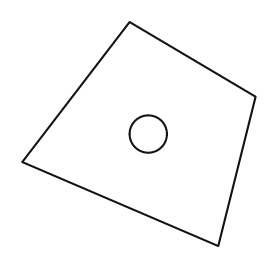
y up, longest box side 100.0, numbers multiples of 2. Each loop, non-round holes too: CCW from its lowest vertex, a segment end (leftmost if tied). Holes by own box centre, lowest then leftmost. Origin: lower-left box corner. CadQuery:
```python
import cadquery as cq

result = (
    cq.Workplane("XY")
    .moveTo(84.0, 0.0)
    .lineTo(100.0, 64.0)
    .lineTo(46.0, 96.0)
    .lineTo(0.0, 36.0)
    .close()
    .moveTo(54.0, 48.0)
    .circle(8.0)
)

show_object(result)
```